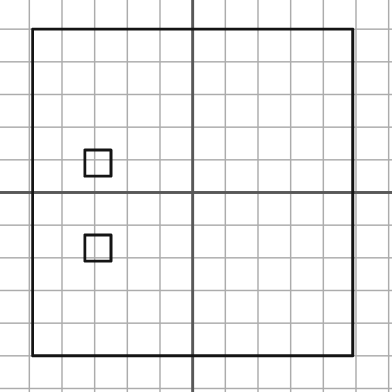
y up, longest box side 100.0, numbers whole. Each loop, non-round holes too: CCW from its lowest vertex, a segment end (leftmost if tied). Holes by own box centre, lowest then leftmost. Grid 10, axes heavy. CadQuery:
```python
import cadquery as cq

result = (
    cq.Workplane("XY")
    .moveTo(-49.0, -50.0)
    .lineTo(49.0, -50.0)
    .lineTo(49.0, 50.0)
    .lineTo(-49.0, 50.0)
    .close()
    .moveTo(-33.0, -21.0)
    .lineTo(-25.0, -21.0)
    .lineTo(-25.0, -13.0)
    .lineTo(-33.0, -13.0)
    .close()
    .moveTo(-33.0, 5.0)
    .lineTo(-25.0, 5.0)
    .lineTo(-25.0, 13.0)
    .lineTo(-33.0, 13.0)
    .close()
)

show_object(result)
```